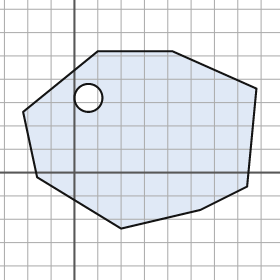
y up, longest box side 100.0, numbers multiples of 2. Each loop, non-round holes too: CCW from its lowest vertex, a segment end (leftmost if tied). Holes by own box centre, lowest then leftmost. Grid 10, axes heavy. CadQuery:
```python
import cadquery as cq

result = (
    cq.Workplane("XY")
    .moveTo(20.0, -24.0)
    .lineTo(54.0, -16.0)
    .lineTo(74.0, -6.0)
    .lineTo(78.0, 36.0)
    .lineTo(42.0, 52.0)
    .lineTo(10.0, 52.0)
    .lineTo(-22.0, 26.0)
    .lineTo(-16.0, -2.0)
    .close()
    .moveTo(6.0, 32.0)
    .circle(6.0)
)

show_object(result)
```